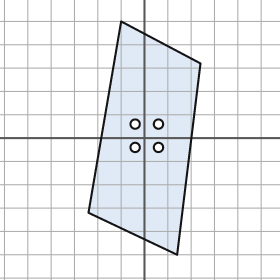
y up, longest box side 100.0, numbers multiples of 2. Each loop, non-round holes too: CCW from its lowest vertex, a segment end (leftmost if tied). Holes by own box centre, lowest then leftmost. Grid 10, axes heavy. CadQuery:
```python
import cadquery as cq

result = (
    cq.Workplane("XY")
    .moveTo(14.0, -50.0)
    .lineTo(24.0, 32.0)
    .lineTo(-10.0, 50.0)
    .lineTo(-24.0, -32.0)
    .close()
    .moveTo(-4.0, -4.0)
    .circle(2.0)
    .moveTo(6.0, -4.0)
    .circle(2.0)
    .moveTo(-4.0, 6.0)
    .circle(2.0)
    .moveTo(6.0, 6.0)
    .circle(2.0)
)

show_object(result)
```